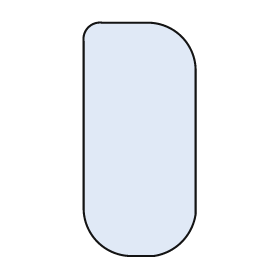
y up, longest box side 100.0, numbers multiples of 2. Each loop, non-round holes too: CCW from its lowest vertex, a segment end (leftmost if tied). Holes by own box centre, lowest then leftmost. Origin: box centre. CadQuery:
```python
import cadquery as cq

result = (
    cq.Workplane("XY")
    .moveTo(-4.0, -50.0)
    .lineTo(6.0, -50.0)
    .threePointArc((18.0, -44.0), (24.0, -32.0))
    .lineTo(24.0, 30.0)
    .threePointArc((18.0, 44.0), (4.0, 50.0))
    .lineTo(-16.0, 50.0)
    .threePointArc((-22.0, 48.0), (-24.0, 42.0))
    .lineTo(-24.0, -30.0)
    .threePointArc((-18.0, -44.0), (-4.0, -50.0))
    .close()
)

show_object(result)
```